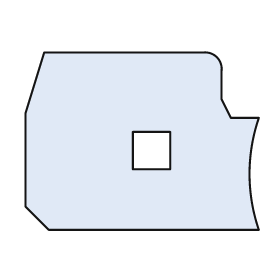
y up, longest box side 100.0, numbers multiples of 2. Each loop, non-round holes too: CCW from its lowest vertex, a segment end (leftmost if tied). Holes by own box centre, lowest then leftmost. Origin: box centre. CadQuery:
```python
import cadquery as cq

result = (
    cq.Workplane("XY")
    .moveTo(-40.0, -38.0)
    .lineTo(50.0, -38.0)
    .threePointArc((46.0, -14.0), (50.0, 10.0))
    .lineTo(38.0, 10.0)
    .lineTo(34.0, 18.0)
    .lineTo(34.0, 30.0)
    .threePointArc((32.0, 36.0), (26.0, 38.0))
    .lineTo(-42.0, 38.0)
    .lineTo(-50.0, 12.0)
    .lineTo(-50.0, -28.0)
    .close()
    .moveTo(-4.0, -12.0)
    .lineTo(12.0, -12.0)
    .lineTo(12.0, 4.0)
    .lineTo(-4.0, 4.0)
    .close()
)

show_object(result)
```